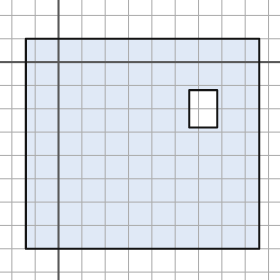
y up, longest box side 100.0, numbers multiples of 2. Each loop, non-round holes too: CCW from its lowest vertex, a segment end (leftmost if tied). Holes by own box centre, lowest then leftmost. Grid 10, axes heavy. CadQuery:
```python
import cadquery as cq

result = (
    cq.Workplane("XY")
    .moveTo(-14.0, -80.0)
    .lineTo(86.0, -80.0)
    .lineTo(86.0, 10.0)
    .lineTo(-14.0, 10.0)
    .close()
    .moveTo(56.0, -28.0)
    .lineTo(68.0, -28.0)
    .lineTo(68.0, -12.0)
    .lineTo(56.0, -12.0)
    .close()
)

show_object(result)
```